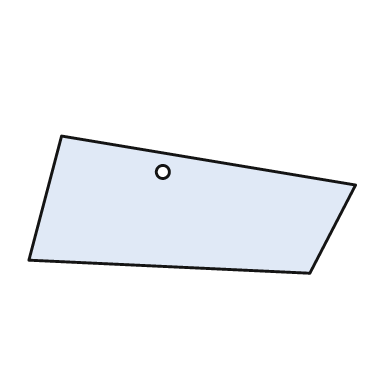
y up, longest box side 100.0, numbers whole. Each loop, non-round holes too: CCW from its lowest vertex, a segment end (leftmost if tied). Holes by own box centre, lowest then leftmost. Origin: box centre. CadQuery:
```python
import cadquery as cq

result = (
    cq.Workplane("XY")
    .moveTo(36.0, -21.0)
    .lineTo(50.0, 6.0)
    .lineTo(-40.0, 21.0)
    .lineTo(-50.0, -17.0)
    .close()
    .moveTo(-9.0, 10.0)
    .circle(2.0)
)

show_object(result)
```